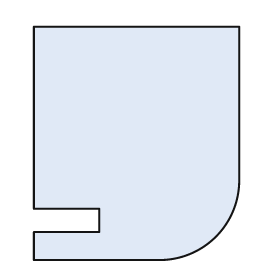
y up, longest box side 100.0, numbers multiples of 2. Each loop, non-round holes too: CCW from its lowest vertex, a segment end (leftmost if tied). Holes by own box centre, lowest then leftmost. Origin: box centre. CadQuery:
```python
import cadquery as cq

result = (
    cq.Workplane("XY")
    .moveTo(-44.0, -50.0)
    .lineTo(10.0, -50.0)
    .threePointArc((34.0, -40.0), (44.0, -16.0))
    .lineTo(44.0, 50.0)
    .lineTo(-44.0, 50.0)
    .lineTo(-44.0, -28.0)
    .lineTo(-16.0, -28.0)
    .lineTo(-16.0, -38.0)
    .lineTo(-44.0, -38.0)
    .close()
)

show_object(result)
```